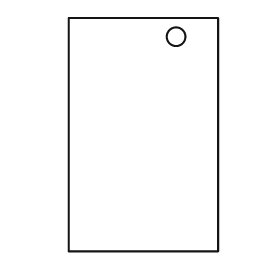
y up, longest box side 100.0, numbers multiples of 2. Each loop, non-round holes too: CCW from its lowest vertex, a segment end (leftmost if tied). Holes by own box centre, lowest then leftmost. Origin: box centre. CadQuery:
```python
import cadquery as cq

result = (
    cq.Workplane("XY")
    .moveTo(-32.0, -50.0)
    .lineTo(32.0, -50.0)
    .lineTo(32.0, 50.0)
    .lineTo(-32.0, 50.0)
    .close()
    .moveTo(14.0, 42.0)
    .circle(4.0)
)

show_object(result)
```